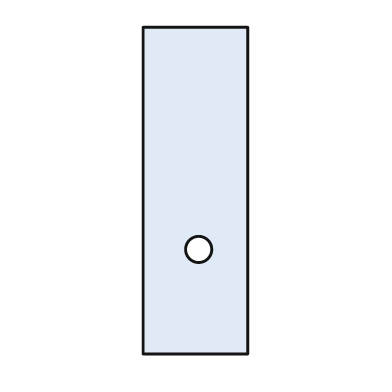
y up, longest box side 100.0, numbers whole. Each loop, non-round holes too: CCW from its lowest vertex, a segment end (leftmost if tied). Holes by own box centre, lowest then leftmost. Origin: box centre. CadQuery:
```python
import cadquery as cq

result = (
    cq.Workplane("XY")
    .moveTo(-16.0, -50.0)
    .lineTo(16.0, -50.0)
    .lineTo(16.0, 50.0)
    .lineTo(-16.0, 50.0)
    .close()
    .moveTo(1.0, -18.0)
    .circle(4.0)
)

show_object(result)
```